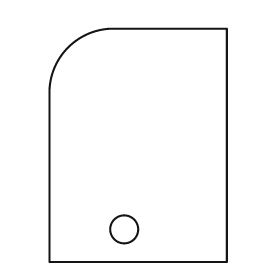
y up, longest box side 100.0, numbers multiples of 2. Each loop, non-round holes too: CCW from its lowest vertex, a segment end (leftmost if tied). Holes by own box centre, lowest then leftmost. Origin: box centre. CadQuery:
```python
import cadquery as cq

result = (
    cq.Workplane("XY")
    .moveTo(-38.0, -50.0)
    .lineTo(38.0, -50.0)
    .lineTo(38.0, 50.0)
    .lineTo(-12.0, 50.0)
    .threePointArc((-30.0, 42.0), (-38.0, 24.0))
    .close()
    .moveTo(-6.0, -36.0)
    .circle(6.0)
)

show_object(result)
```